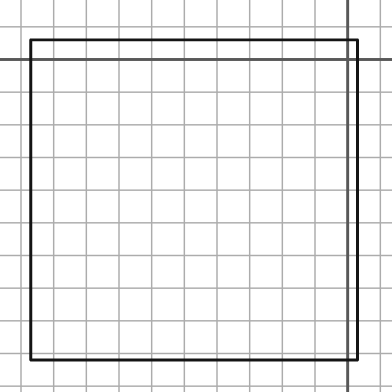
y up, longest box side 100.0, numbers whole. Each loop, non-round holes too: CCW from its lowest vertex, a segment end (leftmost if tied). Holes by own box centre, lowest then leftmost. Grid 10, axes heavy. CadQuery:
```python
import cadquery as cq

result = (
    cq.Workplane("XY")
    .moveTo(-97.0, -92.0)
    .lineTo(3.0, -92.0)
    .lineTo(3.0, 6.0)
    .lineTo(-97.0, 6.0)
    .close()
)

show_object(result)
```